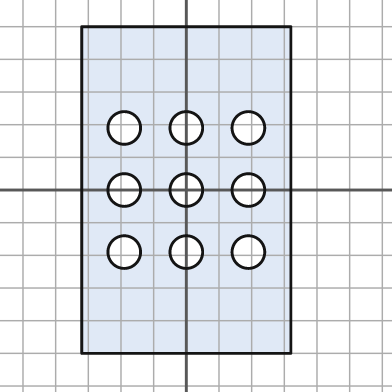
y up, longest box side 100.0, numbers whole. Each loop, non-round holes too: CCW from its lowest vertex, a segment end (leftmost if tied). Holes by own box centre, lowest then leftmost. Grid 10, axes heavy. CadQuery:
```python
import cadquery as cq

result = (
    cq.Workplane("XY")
    .moveTo(-32.0, -50.0)
    .lineTo(32.0, -50.0)
    .lineTo(32.0, 50.0)
    .lineTo(-32.0, 50.0)
    .close()
    .moveTo(-19.0, -19.0)
    .circle(5.0)
    .moveTo(0.0, -19.0)
    .circle(5.0)
    .moveTo(19.0, -19.0)
    .circle(5.0)
    .moveTo(-19.0, 0.0)
    .circle(5.0)
    .moveTo(0.0, 0.0)
    .circle(5.0)
    .moveTo(19.0, 0.0)
    .circle(5.0)
    .moveTo(-19.0, 19.0)
    .circle(5.0)
    .moveTo(0.0, 19.0)
    .circle(5.0)
    .moveTo(19.0, 19.0)
    .circle(5.0)
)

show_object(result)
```